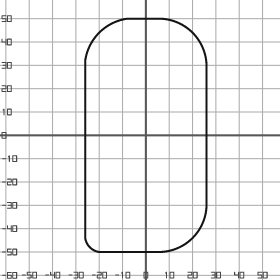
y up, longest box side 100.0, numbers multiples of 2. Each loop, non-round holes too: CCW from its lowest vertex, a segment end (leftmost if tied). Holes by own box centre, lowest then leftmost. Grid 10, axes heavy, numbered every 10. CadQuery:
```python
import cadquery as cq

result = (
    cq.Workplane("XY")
    .moveTo(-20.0, -50.0)
    .lineTo(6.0, -50.0)
    .threePointArc((20.0, -44.0), (26.0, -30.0))
    .lineTo(26.0, 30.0)
    .threePointArc((20.0, 44.0), (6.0, 50.0))
    .lineTo(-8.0, 50.0)
    .threePointArc((-20.0, 44.0), (-26.0, 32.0))
    .lineTo(-26.0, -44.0)
    .threePointArc((-24.0, -48.0), (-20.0, -50.0))
    .close()
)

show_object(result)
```